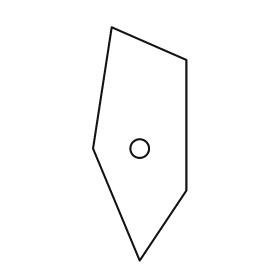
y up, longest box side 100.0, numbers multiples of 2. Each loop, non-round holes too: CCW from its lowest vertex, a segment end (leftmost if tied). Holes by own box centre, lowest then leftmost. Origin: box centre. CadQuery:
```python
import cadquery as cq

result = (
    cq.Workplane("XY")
    .moveTo(0.0, -50.0)
    .lineTo(20.0, -20.0)
    .lineTo(20.0, 36.0)
    .lineTo(-12.0, 50.0)
    .lineTo(-20.0, -2.0)
    .close()
    .moveTo(0.0, -2.0)
    .circle(4.0)
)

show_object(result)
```